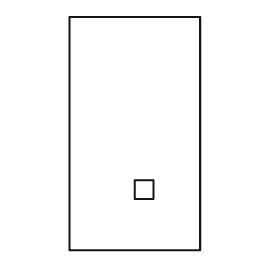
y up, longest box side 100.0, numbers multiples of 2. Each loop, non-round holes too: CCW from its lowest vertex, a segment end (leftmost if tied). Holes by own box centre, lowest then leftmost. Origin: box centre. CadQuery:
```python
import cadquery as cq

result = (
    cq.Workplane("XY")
    .moveTo(-28.0, -50.0)
    .lineTo(28.0, -50.0)
    .lineTo(28.0, 50.0)
    .lineTo(-28.0, 50.0)
    .close()
    .moveTo(0.0, -28.0)
    .lineTo(8.0, -28.0)
    .lineTo(8.0, -20.0)
    .lineTo(0.0, -20.0)
    .close()
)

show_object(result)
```